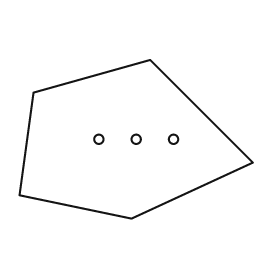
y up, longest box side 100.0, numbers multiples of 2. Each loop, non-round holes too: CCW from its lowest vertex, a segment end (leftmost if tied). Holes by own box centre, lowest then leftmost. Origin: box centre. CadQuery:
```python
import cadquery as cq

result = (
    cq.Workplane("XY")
    .moveTo(-2.0, -34.0)
    .lineTo(50.0, -10.0)
    .lineTo(6.0, 34.0)
    .lineTo(-44.0, 20.0)
    .lineTo(-50.0, -24.0)
    .close()
    .moveTo(-16.0, 0.0)
    .circle(2.0)
    .moveTo(0.0, 0.0)
    .circle(2.0)
    .moveTo(16.0, 0.0)
    .circle(2.0)
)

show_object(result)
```